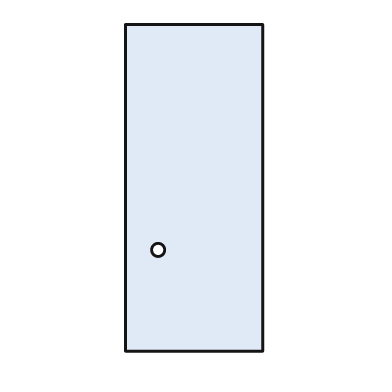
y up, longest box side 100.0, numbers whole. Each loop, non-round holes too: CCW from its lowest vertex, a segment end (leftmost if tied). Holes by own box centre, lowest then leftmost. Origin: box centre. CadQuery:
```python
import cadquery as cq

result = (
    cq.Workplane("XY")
    .moveTo(-21.0, -50.0)
    .lineTo(21.0, -50.0)
    .lineTo(21.0, 50.0)
    .lineTo(-21.0, 50.0)
    .close()
    .moveTo(-11.0, -19.0)
    .circle(2.0)
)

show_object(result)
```